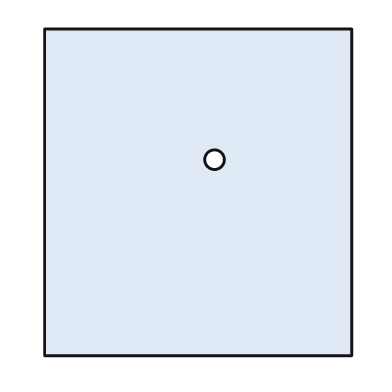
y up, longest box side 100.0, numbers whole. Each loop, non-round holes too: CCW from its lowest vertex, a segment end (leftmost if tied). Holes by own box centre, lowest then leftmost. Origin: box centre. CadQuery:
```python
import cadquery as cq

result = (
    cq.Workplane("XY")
    .moveTo(-47.0, -50.0)
    .lineTo(47.0, -50.0)
    .lineTo(47.0, 50.0)
    .lineTo(-47.0, 50.0)
    .close()
    .moveTo(5.0, 10.0)
    .circle(3.0)
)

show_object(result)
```